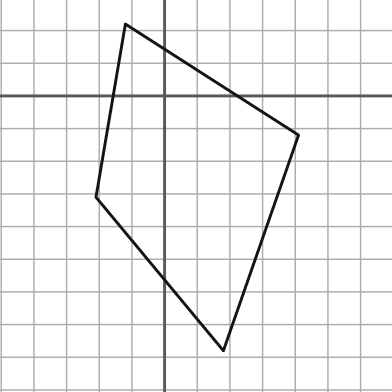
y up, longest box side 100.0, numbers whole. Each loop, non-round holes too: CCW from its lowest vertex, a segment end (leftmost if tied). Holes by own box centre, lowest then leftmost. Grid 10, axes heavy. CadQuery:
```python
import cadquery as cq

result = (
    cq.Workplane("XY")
    .moveTo(18.0, -78.0)
    .lineTo(41.0, -12.0)
    .lineTo(-12.0, 22.0)
    .lineTo(-21.0, -31.0)
    .close()
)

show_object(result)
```